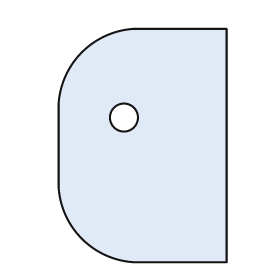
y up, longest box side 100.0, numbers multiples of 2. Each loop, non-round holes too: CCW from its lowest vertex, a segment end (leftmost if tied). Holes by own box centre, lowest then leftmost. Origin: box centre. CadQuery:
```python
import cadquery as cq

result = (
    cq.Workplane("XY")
    .moveTo(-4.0, -50.0)
    .lineTo(36.0, -50.0)
    .lineTo(36.0, 50.0)
    .lineTo(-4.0, 50.0)
    .threePointArc((-26.0, 40.0), (-36.0, 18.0))
    .lineTo(-36.0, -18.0)
    .threePointArc((-26.0, -40.0), (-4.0, -50.0))
    .close()
    .moveTo(-8.0, 12.0)
    .circle(6.0)
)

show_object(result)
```